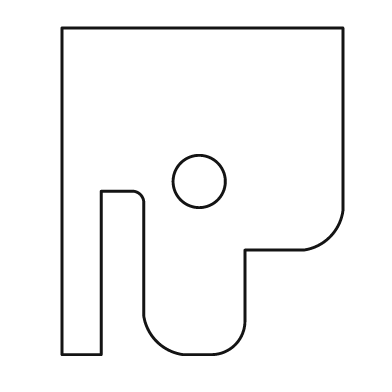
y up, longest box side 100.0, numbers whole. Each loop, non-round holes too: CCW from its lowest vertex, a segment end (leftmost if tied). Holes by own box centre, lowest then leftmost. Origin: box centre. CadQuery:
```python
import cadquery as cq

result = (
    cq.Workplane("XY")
    .moveTo(-43.0, -50.0)
    .lineTo(-31.0, -50.0)
    .lineTo(-31.0, 0.0)
    .lineTo(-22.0, 0.0)
    .threePointArc((-19.0, -1.0), (-18.0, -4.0))
    .lineTo(-18.0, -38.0)
    .threePointArc((-14.0, -46.0), (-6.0, -50.0))
    .lineTo(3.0, -50.0)
    .threePointArc((10.0, -47.0), (13.0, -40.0))
    .lineTo(13.0, -18.0)
    .lineTo(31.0, -18.0)
    .threePointArc((39.0, -14.0), (43.0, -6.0))
    .lineTo(43.0, 50.0)
    .lineTo(-43.0, 50.0)
    .close()
    .moveTo(-1.0, 3.0)
    .circle(8.0)
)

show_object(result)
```